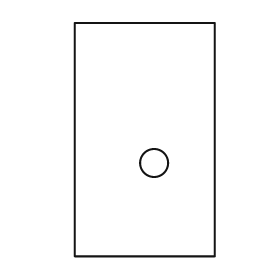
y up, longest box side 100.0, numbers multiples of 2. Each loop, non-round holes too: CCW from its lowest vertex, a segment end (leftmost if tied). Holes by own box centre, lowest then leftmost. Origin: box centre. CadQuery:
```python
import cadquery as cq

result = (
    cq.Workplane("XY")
    .moveTo(-30.0, -50.0)
    .lineTo(30.0, -50.0)
    .lineTo(30.0, 50.0)
    .lineTo(-30.0, 50.0)
    .close()
    .moveTo(4.0, -10.0)
    .circle(6.0)
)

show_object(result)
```